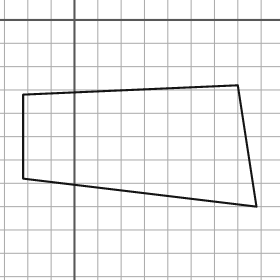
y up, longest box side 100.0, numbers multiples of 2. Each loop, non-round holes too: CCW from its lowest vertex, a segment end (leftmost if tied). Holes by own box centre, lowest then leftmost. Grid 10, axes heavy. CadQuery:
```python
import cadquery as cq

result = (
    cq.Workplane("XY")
    .moveTo(78.0, -80.0)
    .lineTo(70.0, -28.0)
    .lineTo(-22.0, -32.0)
    .lineTo(-22.0, -68.0)
    .close()
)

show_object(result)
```